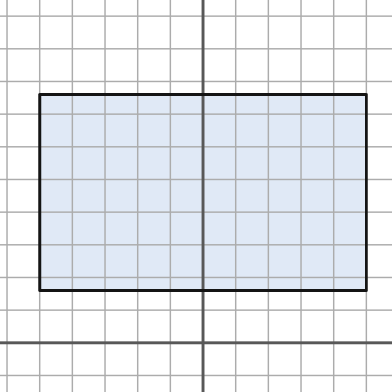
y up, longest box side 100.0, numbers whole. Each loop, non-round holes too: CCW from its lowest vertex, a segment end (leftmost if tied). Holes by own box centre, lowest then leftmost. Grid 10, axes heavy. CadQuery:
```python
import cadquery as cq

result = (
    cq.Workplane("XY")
    .moveTo(-50.0, 16.0)
    .lineTo(50.0, 16.0)
    .lineTo(50.0, 76.0)
    .lineTo(-50.0, 76.0)
    .close()
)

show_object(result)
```